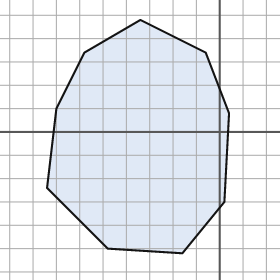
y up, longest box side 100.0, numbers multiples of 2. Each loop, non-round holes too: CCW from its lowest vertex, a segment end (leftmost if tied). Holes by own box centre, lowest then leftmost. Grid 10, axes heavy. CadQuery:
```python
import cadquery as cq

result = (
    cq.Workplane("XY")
    .moveTo(-16.0, -52.0)
    .lineTo(2.0, -30.0)
    .lineTo(4.0, 8.0)
    .lineTo(-6.0, 34.0)
    .lineTo(-34.0, 48.0)
    .lineTo(-58.0, 34.0)
    .lineTo(-70.0, 10.0)
    .lineTo(-74.0, -24.0)
    .lineTo(-48.0, -50.0)
    .close()
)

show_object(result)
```